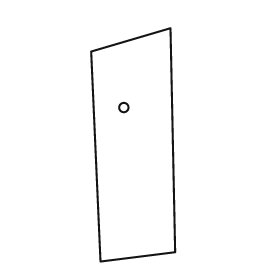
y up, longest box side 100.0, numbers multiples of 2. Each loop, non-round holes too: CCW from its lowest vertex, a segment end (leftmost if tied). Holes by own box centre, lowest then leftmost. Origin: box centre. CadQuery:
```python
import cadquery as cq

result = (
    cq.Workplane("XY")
    .moveTo(-14.0, -50.0)
    .lineTo(18.0, -46.0)
    .lineTo(16.0, 50.0)
    .lineTo(-18.0, 40.0)
    .close()
    .moveTo(-4.0, 16.0)
    .circle(2.0)
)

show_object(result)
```